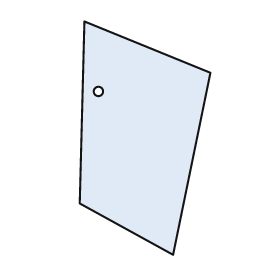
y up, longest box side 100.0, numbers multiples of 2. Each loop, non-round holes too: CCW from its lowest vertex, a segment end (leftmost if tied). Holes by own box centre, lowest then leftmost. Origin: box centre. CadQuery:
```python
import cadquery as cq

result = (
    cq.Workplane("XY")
    .moveTo(12.0, -50.0)
    .lineTo(28.0, 28.0)
    .lineTo(-26.0, 50.0)
    .lineTo(-28.0, -28.0)
    .close()
    .moveTo(-20.0, 20.0)
    .circle(2.0)
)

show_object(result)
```